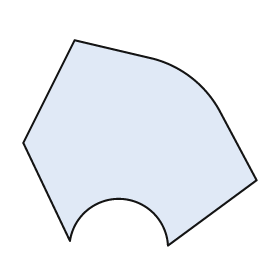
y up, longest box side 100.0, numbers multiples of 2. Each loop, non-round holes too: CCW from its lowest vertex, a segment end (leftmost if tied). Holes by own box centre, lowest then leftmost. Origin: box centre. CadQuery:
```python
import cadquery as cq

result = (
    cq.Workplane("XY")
    .moveTo(12.0, -44.0)
    .lineTo(50.0, -16.0)
    .lineTo(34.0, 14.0)
    .threePointArc((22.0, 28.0), (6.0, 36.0))
    .lineTo(-28.0, 44.0)
    .lineTo(-50.0, 0.0)
    .lineTo(-30.0, -42.0)
    .threePointArc((-8.0, -24.0), (12.0, -44.0))
    .close()
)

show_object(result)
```